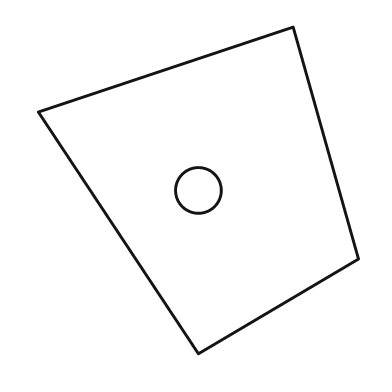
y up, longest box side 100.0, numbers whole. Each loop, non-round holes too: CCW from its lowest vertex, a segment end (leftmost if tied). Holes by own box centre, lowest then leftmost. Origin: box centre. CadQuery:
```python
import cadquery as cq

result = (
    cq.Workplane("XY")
    .moveTo(0.0, -50.0)
    .lineTo(49.0, -21.0)
    .lineTo(29.0, 50.0)
    .lineTo(-49.0, 24.0)
    .close()
    .moveTo(0.0, 0.0)
    .circle(7.0)
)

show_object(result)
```